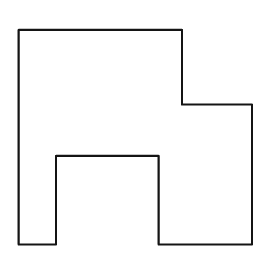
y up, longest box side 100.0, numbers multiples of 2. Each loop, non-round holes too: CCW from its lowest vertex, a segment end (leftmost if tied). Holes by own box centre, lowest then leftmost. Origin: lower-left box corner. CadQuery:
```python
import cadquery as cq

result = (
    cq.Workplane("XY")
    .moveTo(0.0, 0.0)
    .lineTo(16.0, 0.0)
    .lineTo(16.0, 38.0)
    .lineTo(60.0, 38.0)
    .lineTo(60.0, 0.0)
    .lineTo(100.0, 0.0)
    .lineTo(100.0, 60.0)
    .lineTo(70.0, 60.0)
    .lineTo(70.0, 92.0)
    .lineTo(0.0, 92.0)
    .close()
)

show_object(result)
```